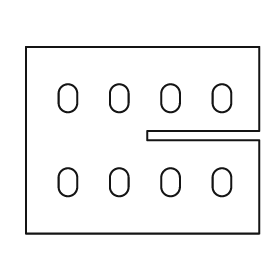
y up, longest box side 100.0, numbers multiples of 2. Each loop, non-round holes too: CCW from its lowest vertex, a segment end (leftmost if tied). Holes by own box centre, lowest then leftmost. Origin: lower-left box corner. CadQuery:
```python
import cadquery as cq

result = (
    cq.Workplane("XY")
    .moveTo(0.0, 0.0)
    .lineTo(100.0, 0.0)
    .lineTo(100.0, 40.0)
    .lineTo(52.0, 40.0)
    .lineTo(52.0, 44.0)
    .lineTo(100.0, 44.0)
    .lineTo(100.0, 80.0)
    .lineTo(0.0, 80.0)
    .close()
    .moveTo(14.0, 20.0)
    .threePointArc((18.0, 16.0), (22.0, 20.0))
    .lineTo(22.0, 24.0)
    .threePointArc((18.0, 28.0), (14.0, 24.0))
    .close()
    .moveTo(36.0, 20.0)
    .threePointArc((40.0, 16.0), (44.0, 20.0))
    .lineTo(44.0, 24.0)
    .threePointArc((40.0, 28.0), (36.0, 24.0))
    .close()
    .moveTo(58.0, 20.0)
    .threePointArc((62.0, 16.0), (66.0, 20.0))
    .lineTo(66.0, 24.0)
    .threePointArc((62.0, 28.0), (58.0, 24.0))
    .close()
    .moveTo(80.0, 20.0)
    .threePointArc((84.0, 16.0), (88.0, 20.0))
    .lineTo(88.0, 24.0)
    .threePointArc((84.0, 28.0), (80.0, 24.0))
    .close()
    .moveTo(14.0, 56.0)
    .threePointArc((18.0, 52.0), (22.0, 56.0))
    .lineTo(22.0, 60.0)
    .threePointArc((18.0, 64.0), (14.0, 60.0))
    .close()
    .moveTo(36.0, 56.0)
    .threePointArc((40.0, 52.0), (44.0, 56.0))
    .lineTo(44.0, 60.0)
    .threePointArc((40.0, 64.0), (36.0, 60.0))
    .close()
    .moveTo(58.0, 56.0)
    .threePointArc((62.0, 52.0), (66.0, 56.0))
    .lineTo(66.0, 60.0)
    .threePointArc((62.0, 64.0), (58.0, 60.0))
    .close()
    .moveTo(80.0, 56.0)
    .threePointArc((84.0, 52.0), (88.0, 56.0))
    .lineTo(88.0, 60.0)
    .threePointArc((84.0, 64.0), (80.0, 60.0))
    .close()
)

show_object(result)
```